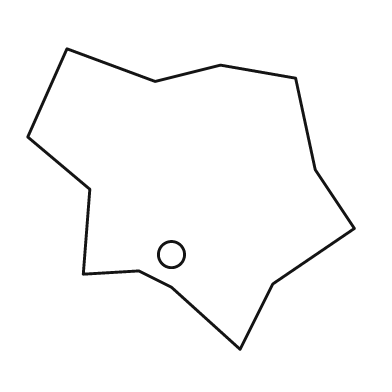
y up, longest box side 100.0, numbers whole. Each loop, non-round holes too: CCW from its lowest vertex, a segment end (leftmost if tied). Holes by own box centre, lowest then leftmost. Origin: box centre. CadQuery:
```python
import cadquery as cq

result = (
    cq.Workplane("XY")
    .moveTo(15.0, -46.0)
    .lineTo(25.0, -26.0)
    .lineTo(50.0, -9.0)
    .lineTo(38.0, 9.0)
    .lineTo(32.0, 37.0)
    .lineTo(9.0, 41.0)
    .lineTo(-11.0, 36.0)
    .lineTo(-38.0, 46.0)
    .lineTo(-50.0, 19.0)
    .lineTo(-31.0, 3.0)
    .lineTo(-33.0, -23.0)
    .lineTo(-16.0, -22.0)
    .lineTo(-6.0, -27.0)
    .close()
    .moveTo(-6.0, -17.0)
    .circle(4.0)
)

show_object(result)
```